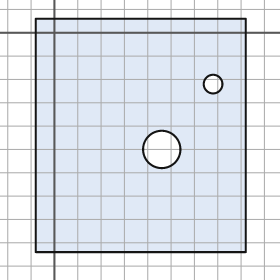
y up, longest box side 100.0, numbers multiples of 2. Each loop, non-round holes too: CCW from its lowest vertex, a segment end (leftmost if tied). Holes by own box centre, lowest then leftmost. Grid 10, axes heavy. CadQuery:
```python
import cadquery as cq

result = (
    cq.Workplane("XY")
    .moveTo(-8.0, -94.0)
    .lineTo(82.0, -94.0)
    .lineTo(82.0, 6.0)
    .lineTo(-8.0, 6.0)
    .close()
    .moveTo(46.0, -50.0)
    .circle(8.0)
    .moveTo(68.0, -22.0)
    .circle(4.0)
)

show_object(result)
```